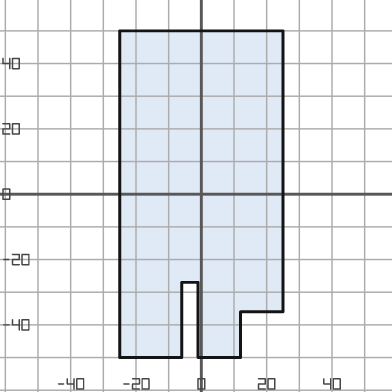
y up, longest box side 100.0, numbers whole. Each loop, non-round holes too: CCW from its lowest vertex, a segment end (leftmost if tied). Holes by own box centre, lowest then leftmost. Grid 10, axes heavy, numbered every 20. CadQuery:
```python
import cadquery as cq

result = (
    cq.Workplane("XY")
    .moveTo(-25.0, -50.0)
    .lineTo(-6.0, -50.0)
    .lineTo(-6.0, -27.0)
    .lineTo(-1.0, -27.0)
    .lineTo(-1.0, -50.0)
    .lineTo(12.0, -50.0)
    .lineTo(12.0, -36.0)
    .lineTo(25.0, -36.0)
    .lineTo(25.0, 50.0)
    .lineTo(-25.0, 50.0)
    .close()
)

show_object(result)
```